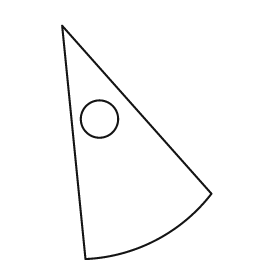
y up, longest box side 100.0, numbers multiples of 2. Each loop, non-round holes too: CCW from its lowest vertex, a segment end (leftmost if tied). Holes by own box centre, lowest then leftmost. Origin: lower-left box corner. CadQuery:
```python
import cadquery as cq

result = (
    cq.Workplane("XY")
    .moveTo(10.0, 0.0)
    .threePointArc((40.0, 8.0), (64.0, 28.0))
    .lineTo(0.0, 100.0)
    .close()
    .moveTo(16.0, 60.0)
    .circle(8.0)
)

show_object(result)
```